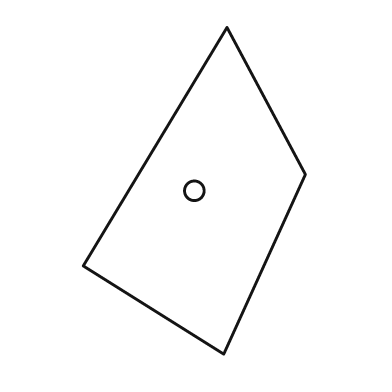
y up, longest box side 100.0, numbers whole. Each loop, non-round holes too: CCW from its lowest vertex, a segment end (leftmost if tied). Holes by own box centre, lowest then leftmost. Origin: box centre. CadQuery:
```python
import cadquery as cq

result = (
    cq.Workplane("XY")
    .moveTo(9.0, -50.0)
    .lineTo(34.0, 5.0)
    .lineTo(10.0, 50.0)
    .lineTo(-34.0, -23.0)
    .close()
    .moveTo(0.0, 0.0)
    .circle(3.0)
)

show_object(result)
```